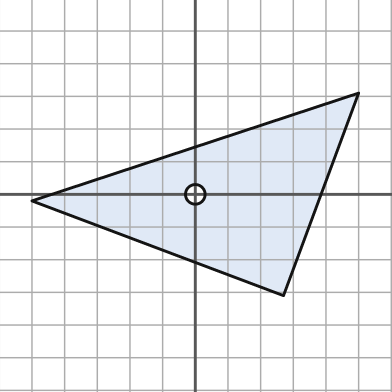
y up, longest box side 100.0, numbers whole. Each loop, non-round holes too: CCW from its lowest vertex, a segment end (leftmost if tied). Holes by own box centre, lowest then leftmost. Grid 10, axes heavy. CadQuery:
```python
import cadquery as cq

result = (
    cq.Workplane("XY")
    .moveTo(27.0, -31.0)
    .lineTo(50.0, 31.0)
    .lineTo(-50.0, -2.0)
    .close()
    .moveTo(0.0, 0.0)
    .circle(3.0)
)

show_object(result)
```